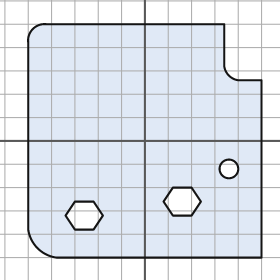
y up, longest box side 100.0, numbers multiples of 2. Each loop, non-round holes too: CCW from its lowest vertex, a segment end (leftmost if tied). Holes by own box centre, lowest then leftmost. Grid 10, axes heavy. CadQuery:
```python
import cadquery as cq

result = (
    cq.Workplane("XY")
    .moveTo(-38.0, -50.0)
    .lineTo(50.0, -50.0)
    .lineTo(50.0, 26.0)
    .lineTo(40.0, 26.0)
    .threePointArc((36.0, 28.0), (34.0, 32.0))
    .lineTo(34.0, 50.0)
    .lineTo(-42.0, 50.0)
    .threePointArc((-48.0, 48.0), (-50.0, 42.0))
    .lineTo(-50.0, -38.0)
    .threePointArc((-46.0, -46.0), (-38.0, -50.0))
    .close()
    .moveTo(-30.0, -38.0)
    .lineTo(-22.0, -38.0)
    .lineTo(-18.0, -32.0)
    .lineTo(-22.0, -26.0)
    .lineTo(-30.0, -26.0)
    .lineTo(-34.0, -32.0)
    .close()
    .moveTo(12.0, -32.0)
    .lineTo(20.0, -32.0)
    .lineTo(24.0, -26.0)
    .lineTo(20.0, -20.0)
    .lineTo(12.0, -20.0)
    .lineTo(8.0, -26.0)
    .close()
    .moveTo(36.0, -12.0)
    .circle(4.0)
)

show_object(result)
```